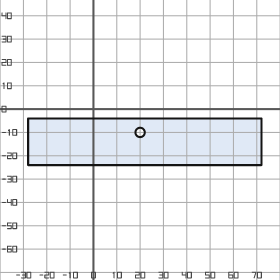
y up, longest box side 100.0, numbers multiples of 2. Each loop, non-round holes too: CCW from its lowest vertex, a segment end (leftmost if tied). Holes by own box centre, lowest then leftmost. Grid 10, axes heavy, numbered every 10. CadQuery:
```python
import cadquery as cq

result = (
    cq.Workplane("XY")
    .moveTo(-28.0, -24.0)
    .lineTo(72.0, -24.0)
    .lineTo(72.0, -4.0)
    .lineTo(-28.0, -4.0)
    .close()
    .moveTo(20.0, -10.0)
    .circle(2.0)
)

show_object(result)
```